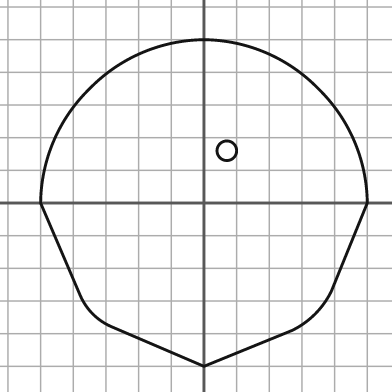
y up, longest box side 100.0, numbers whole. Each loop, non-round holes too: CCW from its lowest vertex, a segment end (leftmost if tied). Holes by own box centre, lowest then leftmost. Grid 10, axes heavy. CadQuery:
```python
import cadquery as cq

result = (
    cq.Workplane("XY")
    .moveTo(0.0, -50.0)
    .lineTo(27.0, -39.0)
    .threePointArc((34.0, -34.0), (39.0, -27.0))
    .lineTo(50.0, 0.0)
    .threePointArc((46.0, 19.0), (35.0, 35.0))
    .threePointArc((19.0, 46.0), (0.0, 50.0))
    .threePointArc((-19.0, 46.0), (-35.0, 35.0))
    .threePointArc((-46.0, 19.0), (-50.0, 0.0))
    .lineTo(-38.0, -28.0)
    .threePointArc((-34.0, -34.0), (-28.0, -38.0))
    .close()
    .moveTo(7.0, 16.0)
    .circle(3.0)
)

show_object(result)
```